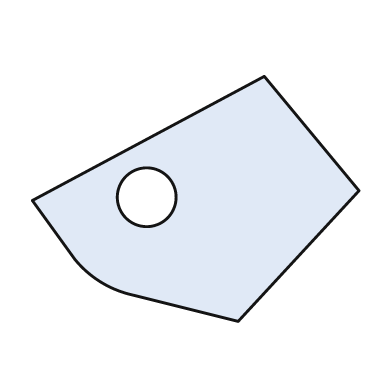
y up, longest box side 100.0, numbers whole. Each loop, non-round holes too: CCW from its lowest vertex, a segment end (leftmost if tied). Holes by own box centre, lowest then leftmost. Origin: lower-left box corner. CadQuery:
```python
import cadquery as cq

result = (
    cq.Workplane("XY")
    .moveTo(63.0, 0.0)
    .lineTo(100.0, 40.0)
    .lineTo(71.0, 75.0)
    .lineTo(0.0, 37.0)
    .lineTo(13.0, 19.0)
    .threePointArc((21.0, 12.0), (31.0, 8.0))
    .close()
    .moveTo(35.0, 38.0)
    .circle(9.0)
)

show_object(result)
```